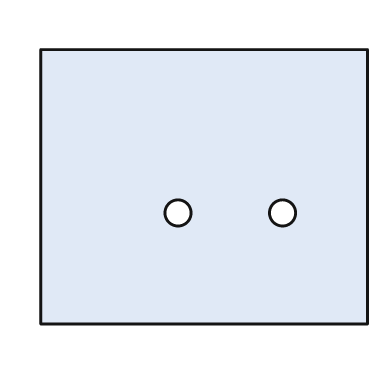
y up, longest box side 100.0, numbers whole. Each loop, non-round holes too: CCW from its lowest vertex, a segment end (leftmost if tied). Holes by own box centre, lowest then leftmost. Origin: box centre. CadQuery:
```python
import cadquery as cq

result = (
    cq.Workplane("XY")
    .moveTo(-50.0, -42.0)
    .lineTo(50.0, -42.0)
    .lineTo(50.0, 42.0)
    .lineTo(-50.0, 42.0)
    .close()
    .moveTo(-8.0, -8.0)
    .circle(4.0)
    .moveTo(24.0, -8.0)
    .circle(4.0)
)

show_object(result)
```